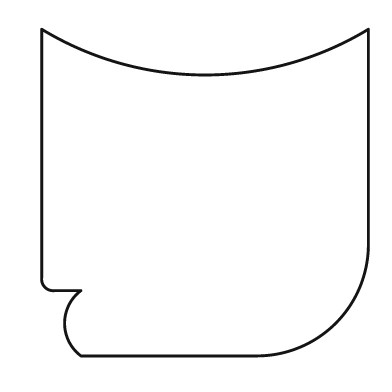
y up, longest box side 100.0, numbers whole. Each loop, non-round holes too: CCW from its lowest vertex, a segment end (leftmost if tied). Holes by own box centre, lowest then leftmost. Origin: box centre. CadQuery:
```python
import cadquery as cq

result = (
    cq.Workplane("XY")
    .moveTo(-38.0, -50.0)
    .lineTo(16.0, -50.0)
    .threePointArc((40.0, -40.0), (50.0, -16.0))
    .lineTo(50.0, 50.0)
    .threePointArc((0.0, 36.0), (-50.0, 50.0))
    .lineTo(-50.0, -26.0)
    .threePointArc((-49.0, -29.0), (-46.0, -30.0))
    .lineTo(-38.0, -30.0)
    .threePointArc((-43.0, -40.0), (-38.0, -50.0))
    .close()
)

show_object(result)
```